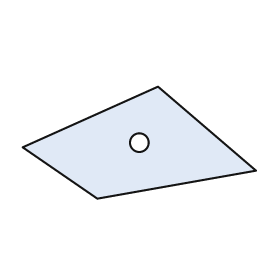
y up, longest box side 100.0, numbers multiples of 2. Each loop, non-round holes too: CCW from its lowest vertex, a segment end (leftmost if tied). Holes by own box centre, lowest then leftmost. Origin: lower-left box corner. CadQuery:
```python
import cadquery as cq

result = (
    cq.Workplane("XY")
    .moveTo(32.0, 0.0)
    .lineTo(100.0, 12.0)
    .lineTo(58.0, 48.0)
    .lineTo(0.0, 22.0)
    .close()
    .moveTo(50.0, 24.0)
    .circle(4.0)
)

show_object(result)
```